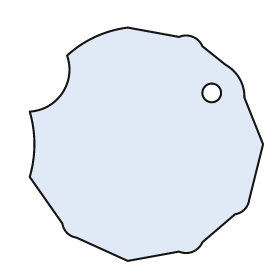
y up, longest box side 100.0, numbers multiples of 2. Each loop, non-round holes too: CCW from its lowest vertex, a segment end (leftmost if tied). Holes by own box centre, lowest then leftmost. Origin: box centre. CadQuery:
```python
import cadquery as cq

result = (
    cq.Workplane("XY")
    .moveTo(-8.0, -50.0)
    .lineTo(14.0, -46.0)
    .threePointArc((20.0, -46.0), (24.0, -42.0))
    .lineTo(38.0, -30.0)
    .threePointArc((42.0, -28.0), (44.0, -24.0))
    .lineTo(50.0, 0.0)
    .lineTo(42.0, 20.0)
    .threePointArc((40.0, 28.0), (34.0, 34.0))
    .lineTo(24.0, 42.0)
    .threePointArc((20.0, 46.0), (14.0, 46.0))
    .lineTo(-8.0, 50.0)
    .threePointArc((-22.0, 46.0), (-34.0, 38.0))
    .threePointArc((-36.0, 22.0), (-50.0, 14.0))
    .threePointArc((-48.0, 0.0), (-50.0, -14.0))
    .lineTo(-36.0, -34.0)
    .threePointArc((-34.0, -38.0), (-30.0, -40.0))
    .close()
    .moveTo(28.0, 22.0)
    .circle(4.0)
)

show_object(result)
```